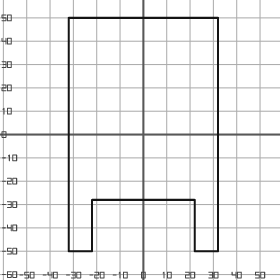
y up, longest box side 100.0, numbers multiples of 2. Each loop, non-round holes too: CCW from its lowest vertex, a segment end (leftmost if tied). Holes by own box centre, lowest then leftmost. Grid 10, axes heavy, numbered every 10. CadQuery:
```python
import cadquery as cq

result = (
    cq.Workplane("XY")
    .moveTo(-32.0, -50.0)
    .lineTo(-22.0, -50.0)
    .lineTo(-22.0, -28.0)
    .lineTo(22.0, -28.0)
    .lineTo(22.0, -50.0)
    .lineTo(32.0, -50.0)
    .lineTo(32.0, 50.0)
    .lineTo(-32.0, 50.0)
    .close()
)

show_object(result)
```